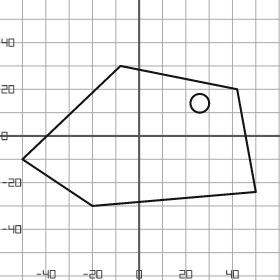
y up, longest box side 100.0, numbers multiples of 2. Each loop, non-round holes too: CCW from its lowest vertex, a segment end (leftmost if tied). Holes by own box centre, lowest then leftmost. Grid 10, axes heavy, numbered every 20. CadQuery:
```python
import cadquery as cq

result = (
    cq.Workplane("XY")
    .moveTo(-20.0, -30.0)
    .lineTo(50.0, -24.0)
    .lineTo(42.0, 20.0)
    .lineTo(-8.0, 30.0)
    .lineTo(-50.0, -10.0)
    .close()
    .moveTo(26.0, 14.0)
    .circle(4.0)
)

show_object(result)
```